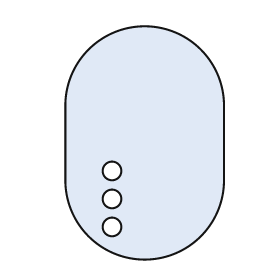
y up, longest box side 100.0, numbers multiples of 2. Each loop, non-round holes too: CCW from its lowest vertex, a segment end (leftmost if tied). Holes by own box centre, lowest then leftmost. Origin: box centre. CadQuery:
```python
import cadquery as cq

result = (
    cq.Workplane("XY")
    .moveTo(-34.0, -16.0)
    .threePointArc((0.0, -50.0), (34.0, -16.0))
    .lineTo(34.0, 16.0)
    .threePointArc((0.0, 50.0), (-34.0, 16.0))
    .close()
    .moveTo(-14.0, -36.0)
    .circle(4.0)
    .moveTo(-14.0, -24.0)
    .circle(4.0)
    .moveTo(-14.0, -12.0)
    .circle(4.0)
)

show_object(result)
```